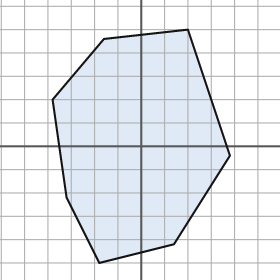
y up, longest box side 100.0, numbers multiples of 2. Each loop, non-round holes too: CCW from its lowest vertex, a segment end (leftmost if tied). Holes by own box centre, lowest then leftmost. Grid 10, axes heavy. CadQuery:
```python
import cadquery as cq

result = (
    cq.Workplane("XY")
    .moveTo(-18.0, -50.0)
    .lineTo(14.0, -42.0)
    .lineTo(38.0, -4.0)
    .lineTo(20.0, 50.0)
    .lineTo(-16.0, 46.0)
    .lineTo(-38.0, 20.0)
    .lineTo(-32.0, -22.0)
    .close()
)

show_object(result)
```